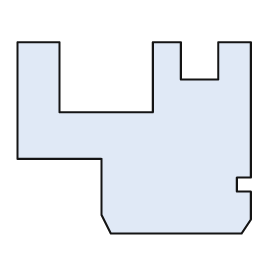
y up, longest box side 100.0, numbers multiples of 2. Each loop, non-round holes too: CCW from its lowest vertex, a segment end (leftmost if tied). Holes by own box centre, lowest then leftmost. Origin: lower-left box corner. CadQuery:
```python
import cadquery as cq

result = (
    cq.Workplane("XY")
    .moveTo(40.0, 0.0)
    .lineTo(96.0, 0.0)
    .lineTo(100.0, 6.0)
    .lineTo(100.0, 18.0)
    .lineTo(94.0, 18.0)
    .lineTo(94.0, 24.0)
    .lineTo(100.0, 24.0)
    .lineTo(100.0, 82.0)
    .lineTo(86.0, 82.0)
    .lineTo(86.0, 66.0)
    .lineTo(70.0, 66.0)
    .lineTo(70.0, 82.0)
    .lineTo(58.0, 82.0)
    .lineTo(58.0, 52.0)
    .lineTo(18.0, 52.0)
    .lineTo(18.0, 82.0)
    .lineTo(0.0, 82.0)
    .lineTo(0.0, 32.0)
    .lineTo(36.0, 32.0)
    .lineTo(36.0, 8.0)
    .close()
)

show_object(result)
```